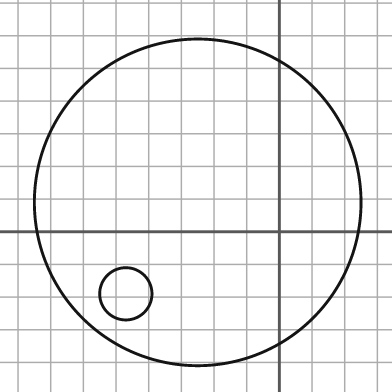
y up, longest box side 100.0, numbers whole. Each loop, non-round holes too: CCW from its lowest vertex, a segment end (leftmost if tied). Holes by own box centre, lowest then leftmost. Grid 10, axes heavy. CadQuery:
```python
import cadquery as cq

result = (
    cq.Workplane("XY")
    .moveTo(-25.0, 9.0)
    .circle(50.0)
    .moveTo(-47.0, -19.0)
    .circle(8.0)
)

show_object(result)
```